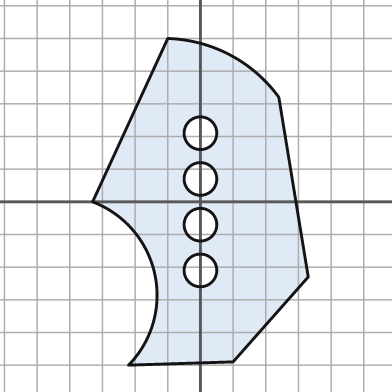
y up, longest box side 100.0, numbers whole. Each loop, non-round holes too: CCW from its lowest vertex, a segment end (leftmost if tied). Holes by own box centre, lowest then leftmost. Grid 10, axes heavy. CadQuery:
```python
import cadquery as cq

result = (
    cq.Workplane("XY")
    .moveTo(-22.0, -50.0)
    .lineTo(10.0, -49.0)
    .lineTo(33.0, -23.0)
    .lineTo(24.0, 32.0)
    .threePointArc((9.0, 45.0), (-10.0, 50.0))
    .lineTo(-33.0, 0.0)
    .threePointArc((-14.0, -22.0), (-22.0, -50.0))
    .close()
    .moveTo(0.0, -21.0)
    .circle(5.0)
    .moveTo(0.0, -7.0)
    .circle(5.0)
    .moveTo(0.0, 7.0)
    .circle(5.0)
    .moveTo(0.0, 21.0)
    .circle(5.0)
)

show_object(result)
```